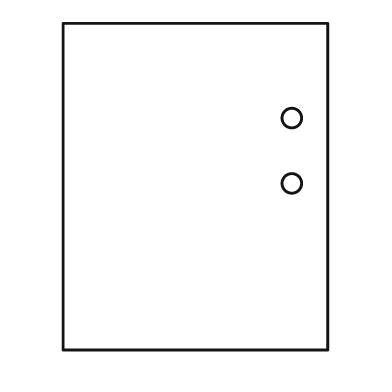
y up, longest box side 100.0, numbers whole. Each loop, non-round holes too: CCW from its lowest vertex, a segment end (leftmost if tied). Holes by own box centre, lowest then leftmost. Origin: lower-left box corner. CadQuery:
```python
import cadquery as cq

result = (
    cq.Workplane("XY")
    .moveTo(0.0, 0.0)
    .lineTo(81.0, 0.0)
    .lineTo(81.0, 100.0)
    .lineTo(0.0, 100.0)
    .close()
    .moveTo(70.0, 51.0)
    .circle(3.0)
    .moveTo(70.0, 71.0)
    .circle(3.0)
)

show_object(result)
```